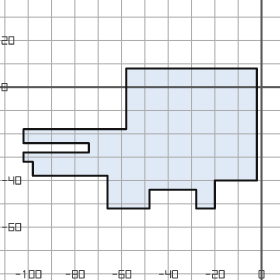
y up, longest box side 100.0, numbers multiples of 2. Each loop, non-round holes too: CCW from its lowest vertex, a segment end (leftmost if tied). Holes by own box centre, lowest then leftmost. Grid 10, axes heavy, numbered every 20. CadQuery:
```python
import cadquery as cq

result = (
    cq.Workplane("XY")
    .moveTo(-66.0, -52.0)
    .lineTo(-48.0, -52.0)
    .lineTo(-48.0, -44.0)
    .lineTo(-28.0, -44.0)
    .lineTo(-28.0, -52.0)
    .lineTo(-20.0, -52.0)
    .lineTo(-20.0, -40.0)
    .lineTo(-2.0, -40.0)
    .lineTo(-2.0, 8.0)
    .lineTo(-58.0, 8.0)
    .lineTo(-58.0, -18.0)
    .lineTo(-102.0, -18.0)
    .lineTo(-102.0, -24.0)
    .lineTo(-74.0, -24.0)
    .lineTo(-74.0, -28.0)
    .lineTo(-102.0, -28.0)
    .lineTo(-102.0, -32.0)
    .lineTo(-98.0, -32.0)
    .lineTo(-98.0, -38.0)
    .lineTo(-66.0, -38.0)
    .close()
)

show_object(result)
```